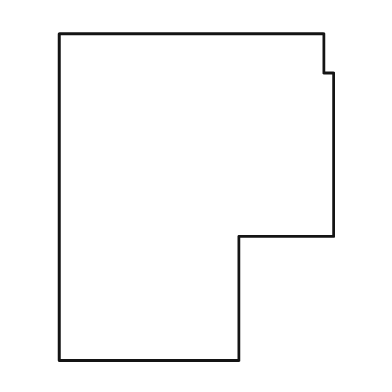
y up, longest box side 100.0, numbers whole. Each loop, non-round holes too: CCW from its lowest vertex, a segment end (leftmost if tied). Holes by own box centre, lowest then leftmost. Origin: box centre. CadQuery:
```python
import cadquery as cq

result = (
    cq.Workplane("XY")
    .moveTo(-42.0, -50.0)
    .lineTo(13.0, -50.0)
    .lineTo(13.0, -12.0)
    .lineTo(42.0, -12.0)
    .lineTo(42.0, 38.0)
    .lineTo(39.0, 38.0)
    .lineTo(39.0, 50.0)
    .lineTo(-42.0, 50.0)
    .close()
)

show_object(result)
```